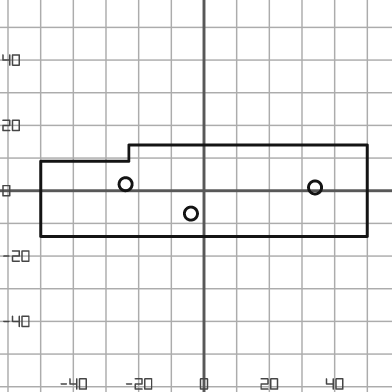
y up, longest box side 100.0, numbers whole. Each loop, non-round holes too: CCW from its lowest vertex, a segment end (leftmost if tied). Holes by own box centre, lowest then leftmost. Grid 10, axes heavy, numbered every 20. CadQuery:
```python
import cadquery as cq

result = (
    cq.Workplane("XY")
    .moveTo(-50.0, -14.0)
    .lineTo(50.0, -14.0)
    .lineTo(50.0, 14.0)
    .lineTo(-23.0, 14.0)
    .lineTo(-23.0, 9.0)
    .lineTo(-50.0, 9.0)
    .close()
    .moveTo(-4.0, -7.0)
    .circle(2.0)
    .moveTo(34.0, 1.0)
    .circle(2.0)
    .moveTo(-24.0, 2.0)
    .circle(2.0)
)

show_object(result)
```